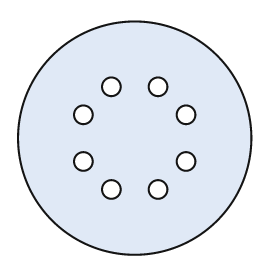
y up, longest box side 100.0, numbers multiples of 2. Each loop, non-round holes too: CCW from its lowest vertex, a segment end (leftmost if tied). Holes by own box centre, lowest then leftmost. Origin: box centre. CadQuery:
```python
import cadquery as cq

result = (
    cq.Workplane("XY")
    .moveTo(0.0, 0.0)
    .circle(50.0)
    .moveTo(-10.0, -22.0)
    .circle(4.0)
    .moveTo(10.0, -22.0)
    .circle(4.0)
    .moveTo(-22.0, -10.0)
    .circle(4.0)
    .moveTo(22.0, -10.0)
    .circle(4.0)
    .moveTo(-22.0, 10.0)
    .circle(4.0)
    .moveTo(22.0, 10.0)
    .circle(4.0)
    .moveTo(-10.0, 22.0)
    .circle(4.0)
    .moveTo(10.0, 22.0)
    .circle(4.0)
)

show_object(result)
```